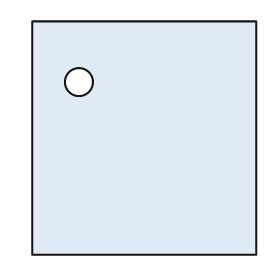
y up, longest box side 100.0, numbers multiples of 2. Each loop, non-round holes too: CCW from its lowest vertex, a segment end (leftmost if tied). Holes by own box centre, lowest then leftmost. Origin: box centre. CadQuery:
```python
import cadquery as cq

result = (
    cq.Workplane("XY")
    .moveTo(-48.0, -50.0)
    .lineTo(48.0, -50.0)
    .lineTo(48.0, 50.0)
    .lineTo(-48.0, 50.0)
    .close()
    .moveTo(-28.0, 24.0)
    .circle(6.0)
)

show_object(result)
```